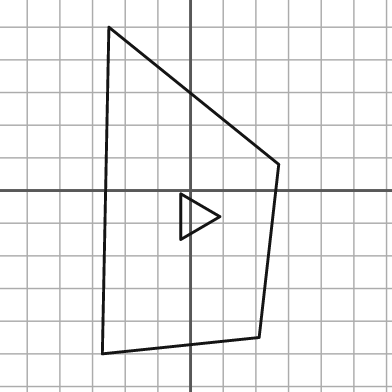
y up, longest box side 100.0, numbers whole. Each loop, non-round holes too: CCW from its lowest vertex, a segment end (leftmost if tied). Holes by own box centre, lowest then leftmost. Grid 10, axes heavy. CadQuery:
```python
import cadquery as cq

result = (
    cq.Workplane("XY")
    .moveTo(-27.0, -50.0)
    .lineTo(21.0, -45.0)
    .lineTo(27.0, 8.0)
    .lineTo(-25.0, 50.0)
    .close()
    .moveTo(-3.0, -15.0)
    .lineTo(9.0, -8.0)
    .lineTo(-3.0, -1.0)
    .close()
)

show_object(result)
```